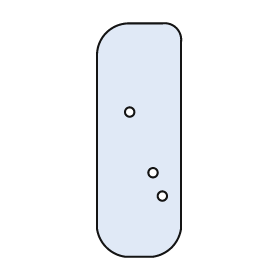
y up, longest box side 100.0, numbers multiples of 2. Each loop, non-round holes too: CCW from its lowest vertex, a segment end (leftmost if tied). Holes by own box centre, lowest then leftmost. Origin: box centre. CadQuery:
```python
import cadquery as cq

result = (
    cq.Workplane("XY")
    .moveTo(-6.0, -50.0)
    .lineTo(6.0, -50.0)
    .threePointArc((14.0, -46.0), (18.0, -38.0))
    .lineTo(18.0, 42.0)
    .threePointArc((16.0, 48.0), (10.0, 50.0))
    .lineTo(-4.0, 50.0)
    .threePointArc((-14.0, 46.0), (-18.0, 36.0))
    .lineTo(-18.0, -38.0)
    .threePointArc((-14.0, -46.0), (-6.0, -50.0))
    .close()
    .moveTo(10.0, -24.0)
    .circle(2.0)
    .moveTo(6.0, -14.0)
    .circle(2.0)
    .moveTo(-4.0, 12.0)
    .circle(2.0)
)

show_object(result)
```